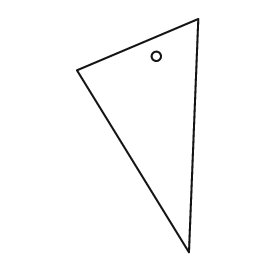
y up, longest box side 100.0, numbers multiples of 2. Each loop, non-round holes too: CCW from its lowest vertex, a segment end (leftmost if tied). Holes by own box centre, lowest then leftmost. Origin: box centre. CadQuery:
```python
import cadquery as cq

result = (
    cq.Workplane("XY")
    .moveTo(22.0, -50.0)
    .lineTo(26.0, 50.0)
    .lineTo(-26.0, 28.0)
    .close()
    .moveTo(8.0, 34.0)
    .circle(2.0)
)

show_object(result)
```